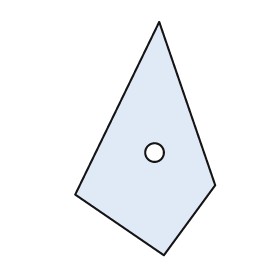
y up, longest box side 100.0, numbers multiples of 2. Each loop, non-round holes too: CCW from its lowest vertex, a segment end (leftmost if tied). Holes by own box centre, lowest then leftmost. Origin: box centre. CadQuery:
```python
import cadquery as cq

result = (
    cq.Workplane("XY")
    .moveTo(8.0, -50.0)
    .lineTo(30.0, -20.0)
    .lineTo(6.0, 50.0)
    .lineTo(-30.0, -24.0)
    .close()
    .moveTo(4.0, -6.0)
    .circle(4.0)
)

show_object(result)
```